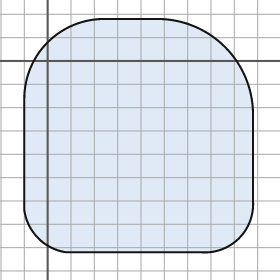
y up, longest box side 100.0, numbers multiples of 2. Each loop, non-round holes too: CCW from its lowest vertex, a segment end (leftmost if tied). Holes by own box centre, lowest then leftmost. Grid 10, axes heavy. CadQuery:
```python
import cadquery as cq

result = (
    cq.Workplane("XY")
    .moveTo(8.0, -82.0)
    .lineTo(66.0, -82.0)
    .threePointArc((82.0, -76.0), (88.0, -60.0))
    .lineTo(88.0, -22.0)
    .threePointArc((76.0, 6.0), (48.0, 18.0))
    .lineTo(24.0, 18.0)
    .threePointArc((0.0, 8.0), (-10.0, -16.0))
    .lineTo(-10.0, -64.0)
    .threePointArc((-4.0, -76.0), (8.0, -82.0))
    .close()
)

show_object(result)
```